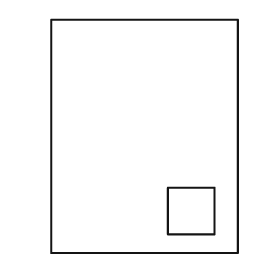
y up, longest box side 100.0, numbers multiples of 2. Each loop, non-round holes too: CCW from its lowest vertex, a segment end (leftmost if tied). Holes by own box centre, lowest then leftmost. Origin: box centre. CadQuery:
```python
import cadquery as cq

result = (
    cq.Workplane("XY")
    .moveTo(-40.0, -50.0)
    .lineTo(40.0, -50.0)
    .lineTo(40.0, 50.0)
    .lineTo(-40.0, 50.0)
    .close()
    .moveTo(10.0, -42.0)
    .lineTo(30.0, -42.0)
    .lineTo(30.0, -22.0)
    .lineTo(10.0, -22.0)
    .close()
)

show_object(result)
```